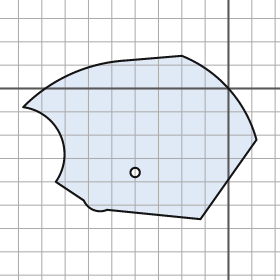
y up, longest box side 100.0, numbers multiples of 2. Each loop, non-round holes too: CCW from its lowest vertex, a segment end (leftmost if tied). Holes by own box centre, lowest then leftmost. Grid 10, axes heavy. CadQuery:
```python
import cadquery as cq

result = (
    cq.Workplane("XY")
    .moveTo(-12.0, -56.0)
    .lineTo(12.0, -22.0)
    .threePointArc((0.0, 0.0), (-20.0, 14.0))
    .lineTo(-44.0, 12.0)
    .threePointArc((-68.0, 6.0), (-88.0, -8.0))
    .threePointArc((-72.0, -20.0), (-74.0, -40.0))
    .lineTo(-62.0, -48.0)
    .threePointArc((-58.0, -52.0), (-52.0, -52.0))
    .close()
    .moveTo(-40.0, -36.0)
    .circle(2.0)
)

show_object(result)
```